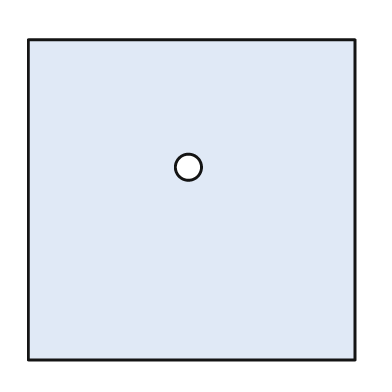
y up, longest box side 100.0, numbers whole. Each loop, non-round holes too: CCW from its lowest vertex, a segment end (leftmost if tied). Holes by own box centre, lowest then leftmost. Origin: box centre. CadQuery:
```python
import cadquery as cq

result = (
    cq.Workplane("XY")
    .moveTo(-50.0, -49.0)
    .lineTo(50.0, -49.0)
    .lineTo(50.0, 49.0)
    .lineTo(-50.0, 49.0)
    .close()
    .moveTo(-1.0, 10.0)
    .circle(4.0)
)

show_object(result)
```